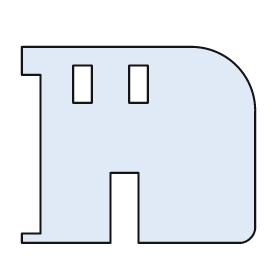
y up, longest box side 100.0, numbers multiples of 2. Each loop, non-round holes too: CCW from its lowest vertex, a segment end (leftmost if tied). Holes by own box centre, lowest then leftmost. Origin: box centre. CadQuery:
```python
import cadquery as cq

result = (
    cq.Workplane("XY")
    .moveTo(-50.0, -42.0)
    .lineTo(-12.0, -42.0)
    .lineTo(-12.0, -12.0)
    .lineTo(0.0, -12.0)
    .lineTo(0.0, -42.0)
    .lineTo(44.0, -42.0)
    .threePointArc((48.0, -40.0), (50.0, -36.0))
    .lineTo(50.0, 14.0)
    .threePointArc((42.0, 34.0), (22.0, 42.0))
    .lineTo(-50.0, 42.0)
    .lineTo(-50.0, 30.0)
    .lineTo(-42.0, 30.0)
    .lineTo(-42.0, -38.0)
    .lineTo(-50.0, -38.0)
    .close()
    .moveTo(-28.0, 18.0)
    .lineTo(-20.0, 18.0)
    .lineTo(-20.0, 34.0)
    .lineTo(-28.0, 34.0)
    .close()
    .moveTo(-4.0, 18.0)
    .lineTo(4.0, 18.0)
    .lineTo(4.0, 34.0)
    .lineTo(-4.0, 34.0)
    .close()
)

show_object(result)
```